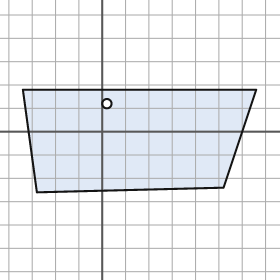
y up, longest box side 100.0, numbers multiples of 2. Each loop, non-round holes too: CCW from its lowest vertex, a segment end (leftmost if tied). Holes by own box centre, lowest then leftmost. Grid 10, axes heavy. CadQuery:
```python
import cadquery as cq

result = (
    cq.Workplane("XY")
    .moveTo(-28.0, -26.0)
    .lineTo(52.0, -24.0)
    .lineTo(66.0, 18.0)
    .lineTo(-34.0, 18.0)
    .close()
    .moveTo(2.0, 12.0)
    .circle(2.0)
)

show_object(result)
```